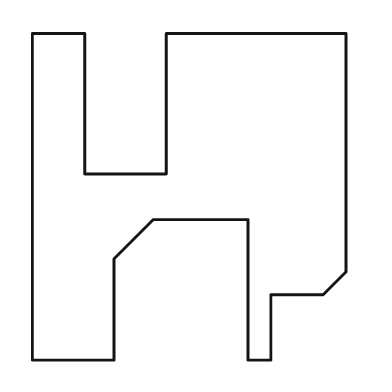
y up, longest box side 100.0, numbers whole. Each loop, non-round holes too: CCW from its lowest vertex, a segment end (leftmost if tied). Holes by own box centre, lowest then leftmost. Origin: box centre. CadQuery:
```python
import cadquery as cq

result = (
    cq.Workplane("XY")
    .moveTo(-48.0, -50.0)
    .lineTo(-23.0, -50.0)
    .lineTo(-23.0, -19.0)
    .lineTo(-11.0, -7.0)
    .lineTo(18.0, -7.0)
    .lineTo(18.0, -50.0)
    .lineTo(25.0, -50.0)
    .lineTo(25.0, -30.0)
    .lineTo(41.0, -30.0)
    .lineTo(48.0, -23.0)
    .lineTo(48.0, 50.0)
    .lineTo(-7.0, 50.0)
    .lineTo(-7.0, 7.0)
    .lineTo(-32.0, 7.0)
    .lineTo(-32.0, 50.0)
    .lineTo(-48.0, 50.0)
    .close()
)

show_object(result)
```